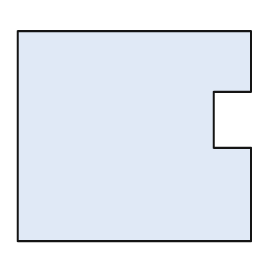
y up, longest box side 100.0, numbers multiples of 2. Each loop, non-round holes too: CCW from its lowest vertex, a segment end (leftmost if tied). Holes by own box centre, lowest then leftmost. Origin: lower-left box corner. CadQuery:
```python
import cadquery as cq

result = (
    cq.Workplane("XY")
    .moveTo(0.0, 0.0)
    .lineTo(100.0, 0.0)
    .lineTo(100.0, 40.0)
    .lineTo(84.0, 40.0)
    .lineTo(84.0, 64.0)
    .lineTo(100.0, 64.0)
    .lineTo(100.0, 90.0)
    .lineTo(0.0, 90.0)
    .close()
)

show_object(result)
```